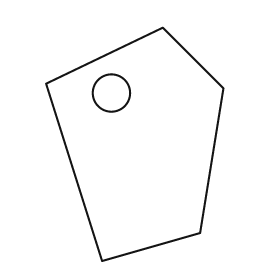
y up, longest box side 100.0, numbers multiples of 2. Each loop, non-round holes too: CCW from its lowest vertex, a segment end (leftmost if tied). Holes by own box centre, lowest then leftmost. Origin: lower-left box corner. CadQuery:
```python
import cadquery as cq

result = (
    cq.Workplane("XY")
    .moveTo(24.0, 0.0)
    .lineTo(66.0, 12.0)
    .lineTo(76.0, 74.0)
    .lineTo(50.0, 100.0)
    .lineTo(0.0, 76.0)
    .close()
    .moveTo(28.0, 72.0)
    .circle(8.0)
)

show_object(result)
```